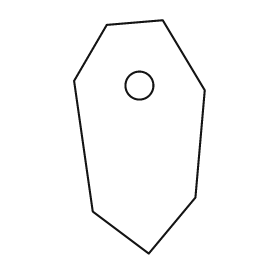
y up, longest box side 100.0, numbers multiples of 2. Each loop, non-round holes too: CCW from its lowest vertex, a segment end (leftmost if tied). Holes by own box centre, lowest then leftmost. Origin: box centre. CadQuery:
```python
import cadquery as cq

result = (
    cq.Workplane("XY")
    .moveTo(4.0, -50.0)
    .lineTo(24.0, -26.0)
    .lineTo(28.0, 20.0)
    .lineTo(10.0, 50.0)
    .lineTo(-14.0, 48.0)
    .lineTo(-28.0, 24.0)
    .lineTo(-20.0, -32.0)
    .close()
    .moveTo(0.0, 22.0)
    .circle(6.0)
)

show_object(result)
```